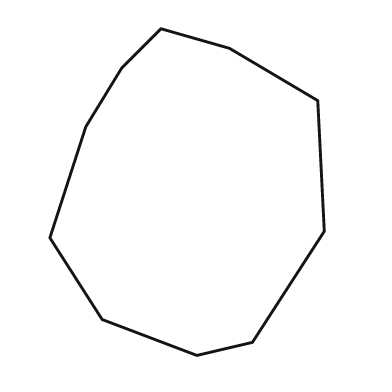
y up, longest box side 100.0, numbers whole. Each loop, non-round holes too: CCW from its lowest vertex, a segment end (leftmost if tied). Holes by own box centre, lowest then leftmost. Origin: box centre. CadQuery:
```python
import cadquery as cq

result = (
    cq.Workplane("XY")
    .moveTo(3.0, -50.0)
    .lineTo(20.0, -46.0)
    .lineTo(42.0, -12.0)
    .lineTo(40.0, 28.0)
    .lineTo(13.0, 44.0)
    .lineTo(-8.0, 50.0)
    .lineTo(-20.0, 38.0)
    .lineTo(-31.0, 20.0)
    .lineTo(-42.0, -14.0)
    .lineTo(-26.0, -39.0)
    .close()
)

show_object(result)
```